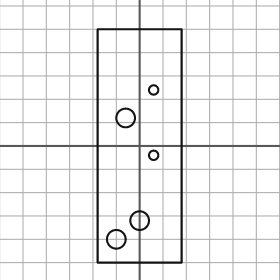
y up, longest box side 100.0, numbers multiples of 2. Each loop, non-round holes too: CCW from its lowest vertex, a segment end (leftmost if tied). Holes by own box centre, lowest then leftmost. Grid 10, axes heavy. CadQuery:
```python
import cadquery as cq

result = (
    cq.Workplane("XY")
    .moveTo(-18.0, -50.0)
    .lineTo(18.0, -50.0)
    .lineTo(18.0, 50.0)
    .lineTo(-18.0, 50.0)
    .close()
    .moveTo(-10.0, -40.0)
    .circle(4.0)
    .moveTo(0.0, -32.0)
    .circle(4.0)
    .moveTo(6.0, -4.0)
    .circle(2.0)
    .moveTo(-6.0, 12.0)
    .circle(4.0)
    .moveTo(6.0, 24.0)
    .circle(2.0)
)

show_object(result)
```